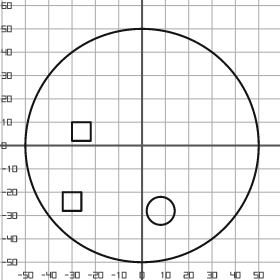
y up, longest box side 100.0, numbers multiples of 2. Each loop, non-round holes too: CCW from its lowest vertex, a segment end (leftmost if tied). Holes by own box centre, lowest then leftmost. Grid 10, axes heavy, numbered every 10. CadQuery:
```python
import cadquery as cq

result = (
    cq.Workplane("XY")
    .moveTo(0.0, 0.0)
    .circle(50.0)
    .moveTo(8.0, -28.0)
    .circle(6.0)
    .moveTo(-34.0, -28.0)
    .lineTo(-26.0, -28.0)
    .lineTo(-26.0, -20.0)
    .lineTo(-34.0, -20.0)
    .close()
    .moveTo(-30.0, 2.0)
    .lineTo(-22.0, 2.0)
    .lineTo(-22.0, 10.0)
    .lineTo(-30.0, 10.0)
    .close()
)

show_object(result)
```